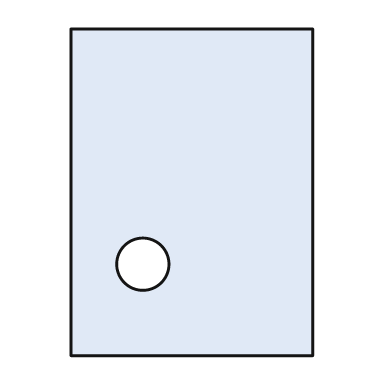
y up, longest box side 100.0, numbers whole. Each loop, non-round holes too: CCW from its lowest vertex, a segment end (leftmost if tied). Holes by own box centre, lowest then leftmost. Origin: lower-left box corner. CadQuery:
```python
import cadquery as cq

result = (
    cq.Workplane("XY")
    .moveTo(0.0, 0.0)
    .lineTo(74.0, 0.0)
    .lineTo(74.0, 100.0)
    .lineTo(0.0, 100.0)
    .close()
    .moveTo(22.0, 28.0)
    .circle(8.0)
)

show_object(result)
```